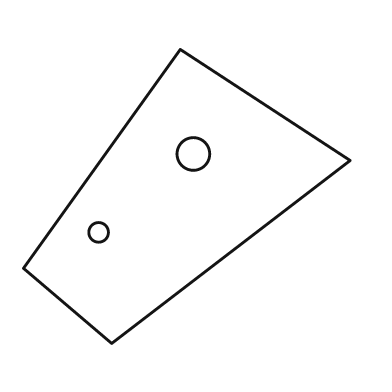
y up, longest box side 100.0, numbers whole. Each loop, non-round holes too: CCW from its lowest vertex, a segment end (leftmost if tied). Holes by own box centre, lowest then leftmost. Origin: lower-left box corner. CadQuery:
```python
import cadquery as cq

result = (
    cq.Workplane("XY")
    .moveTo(27.0, 0.0)
    .lineTo(100.0, 56.0)
    .lineTo(48.0, 90.0)
    .lineTo(0.0, 23.0)
    .close()
    .moveTo(23.0, 34.0)
    .circle(3.0)
    .moveTo(52.0, 58.0)
    .circle(5.0)
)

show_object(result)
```